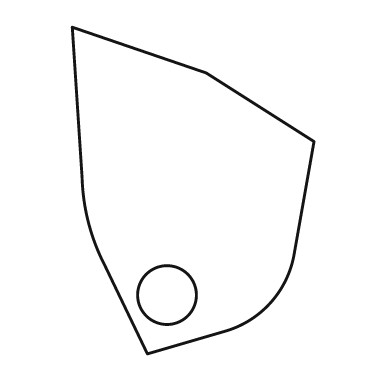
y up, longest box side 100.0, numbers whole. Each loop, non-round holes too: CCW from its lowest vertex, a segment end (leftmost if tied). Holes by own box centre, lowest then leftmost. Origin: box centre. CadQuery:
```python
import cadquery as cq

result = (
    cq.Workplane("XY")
    .moveTo(-14.0, -50.0)
    .lineTo(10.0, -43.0)
    .threePointArc((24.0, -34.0), (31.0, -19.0))
    .lineTo(37.0, 15.0)
    .lineTo(4.0, 36.0)
    .lineTo(-37.0, 50.0)
    .lineTo(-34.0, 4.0)
    .threePointArc((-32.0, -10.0), (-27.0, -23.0))
    .close()
    .moveTo(-8.0, -32.0)
    .circle(9.0)
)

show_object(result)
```